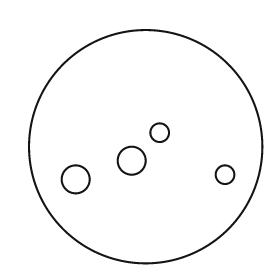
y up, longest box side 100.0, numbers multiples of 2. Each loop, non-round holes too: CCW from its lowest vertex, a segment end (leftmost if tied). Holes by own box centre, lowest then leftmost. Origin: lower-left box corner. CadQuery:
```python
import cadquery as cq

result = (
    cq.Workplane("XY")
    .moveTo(50.0, 50.0)
    .circle(50.0)
    .moveTo(20.0, 36.0)
    .circle(6.0)
    .moveTo(84.0, 38.0)
    .circle(4.0)
    .moveTo(44.0, 44.0)
    .circle(6.0)
    .moveTo(56.0, 56.0)
    .circle(4.0)
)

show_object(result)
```